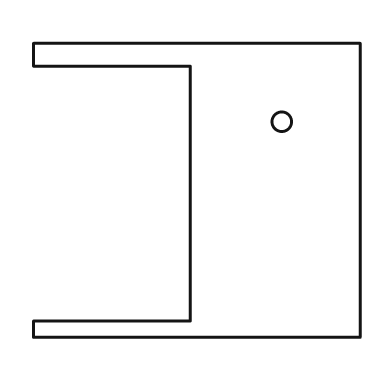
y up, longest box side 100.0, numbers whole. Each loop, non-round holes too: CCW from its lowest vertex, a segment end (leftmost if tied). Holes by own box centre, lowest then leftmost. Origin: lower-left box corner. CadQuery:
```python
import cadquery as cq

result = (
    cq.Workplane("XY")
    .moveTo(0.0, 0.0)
    .lineTo(100.0, 0.0)
    .lineTo(100.0, 90.0)
    .lineTo(0.0, 90.0)
    .lineTo(0.0, 83.0)
    .lineTo(48.0, 83.0)
    .lineTo(48.0, 5.0)
    .lineTo(0.0, 5.0)
    .close()
    .moveTo(76.0, 66.0)
    .circle(3.0)
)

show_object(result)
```